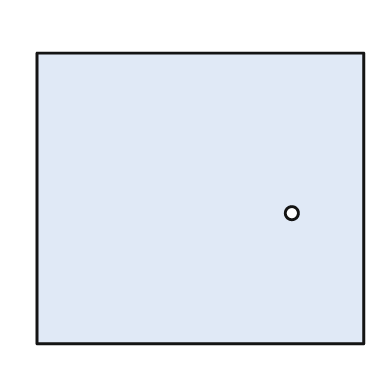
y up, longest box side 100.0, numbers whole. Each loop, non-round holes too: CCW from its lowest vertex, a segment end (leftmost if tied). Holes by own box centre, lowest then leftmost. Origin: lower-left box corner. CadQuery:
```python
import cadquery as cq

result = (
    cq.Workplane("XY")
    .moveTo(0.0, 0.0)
    .lineTo(100.0, 0.0)
    .lineTo(100.0, 89.0)
    .lineTo(0.0, 89.0)
    .close()
    .moveTo(78.0, 40.0)
    .circle(2.0)
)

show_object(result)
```